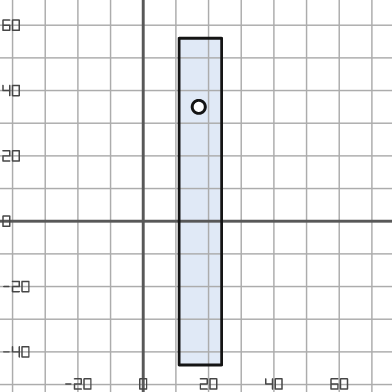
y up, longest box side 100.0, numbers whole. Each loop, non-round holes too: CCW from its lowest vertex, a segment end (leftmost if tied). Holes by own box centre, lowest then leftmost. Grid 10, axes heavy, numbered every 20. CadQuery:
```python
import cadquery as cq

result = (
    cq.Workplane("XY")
    .moveTo(11.0, -44.0)
    .lineTo(24.0, -44.0)
    .lineTo(24.0, 56.0)
    .lineTo(11.0, 56.0)
    .close()
    .moveTo(17.0, 35.0)
    .circle(2.0)
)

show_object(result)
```